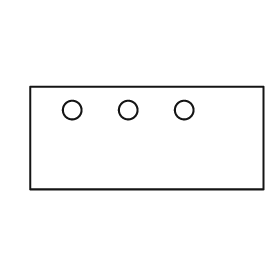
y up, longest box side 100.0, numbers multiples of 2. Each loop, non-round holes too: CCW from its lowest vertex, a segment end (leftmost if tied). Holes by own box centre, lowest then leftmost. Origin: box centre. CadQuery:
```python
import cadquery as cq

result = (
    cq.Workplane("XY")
    .moveTo(-50.0, -22.0)
    .lineTo(50.0, -22.0)
    .lineTo(50.0, 22.0)
    .lineTo(-50.0, 22.0)
    .close()
    .moveTo(-32.0, 12.0)
    .circle(4.0)
    .moveTo(-8.0, 12.0)
    .circle(4.0)
    .moveTo(16.0, 12.0)
    .circle(4.0)
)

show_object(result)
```